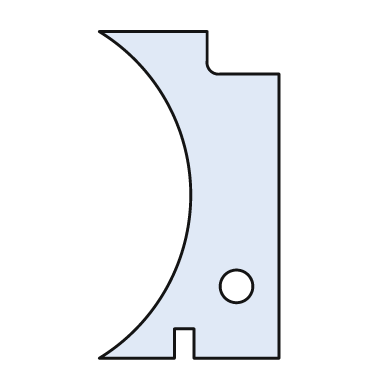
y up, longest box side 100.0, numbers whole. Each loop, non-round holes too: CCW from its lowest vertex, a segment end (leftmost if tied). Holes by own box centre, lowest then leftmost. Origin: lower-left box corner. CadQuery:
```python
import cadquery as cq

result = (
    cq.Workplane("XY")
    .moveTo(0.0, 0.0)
    .lineTo(23.0, 0.0)
    .lineTo(23.0, 9.0)
    .lineTo(29.0, 9.0)
    .lineTo(29.0, 0.0)
    .lineTo(55.0, 0.0)
    .lineTo(55.0, 87.0)
    .lineTo(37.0, 87.0)
    .threePointArc((34.0, 88.0), (33.0, 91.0))
    .lineTo(33.0, 100.0)
    .lineTo(0.0, 100.0)
    .threePointArc((28.0, 50.0), (0.0, 0.0))
    .close()
    .moveTo(42.0, 22.0)
    .circle(5.0)
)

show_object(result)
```